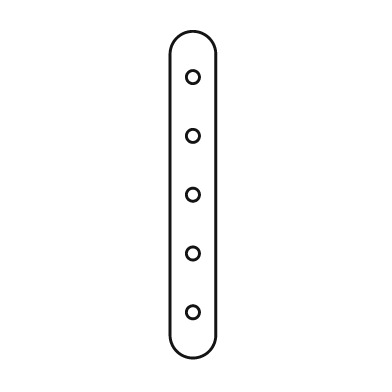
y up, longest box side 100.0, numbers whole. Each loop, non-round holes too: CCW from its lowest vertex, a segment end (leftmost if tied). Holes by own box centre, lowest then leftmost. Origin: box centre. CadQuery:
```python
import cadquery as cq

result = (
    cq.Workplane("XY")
    .moveTo(-7.0, -43.0)
    .threePointArc((0.0, -50.0), (7.0, -43.0))
    .lineTo(7.0, 43.0)
    .threePointArc((0.0, 50.0), (-7.0, 43.0))
    .close()
    .moveTo(0.0, -36.0)
    .circle(2.0)
    .moveTo(0.0, -18.0)
    .circle(2.0)
    .moveTo(0.0, 0.0)
    .circle(2.0)
    .moveTo(0.0, 18.0)
    .circle(2.0)
    .moveTo(0.0, 36.0)
    .circle(2.0)
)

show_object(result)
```